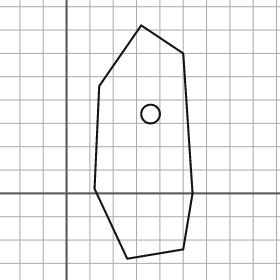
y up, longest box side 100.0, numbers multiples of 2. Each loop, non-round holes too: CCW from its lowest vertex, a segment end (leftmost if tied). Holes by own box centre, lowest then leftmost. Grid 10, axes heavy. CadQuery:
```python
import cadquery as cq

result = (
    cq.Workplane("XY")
    .moveTo(26.0, -28.0)
    .lineTo(50.0, -24.0)
    .lineTo(54.0, 0.0)
    .lineTo(50.0, 60.0)
    .lineTo(32.0, 72.0)
    .lineTo(14.0, 46.0)
    .lineTo(12.0, 2.0)
    .close()
    .moveTo(36.0, 34.0)
    .circle(4.0)
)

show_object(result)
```